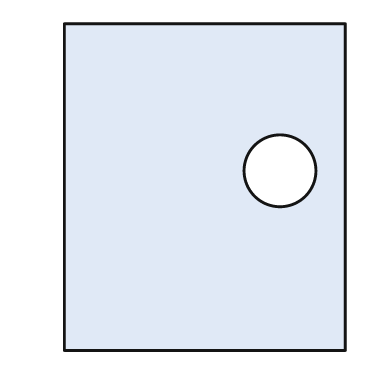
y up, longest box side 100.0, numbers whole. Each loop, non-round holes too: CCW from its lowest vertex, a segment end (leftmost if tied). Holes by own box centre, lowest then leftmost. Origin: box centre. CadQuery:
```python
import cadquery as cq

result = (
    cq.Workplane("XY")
    .moveTo(-43.0, -50.0)
    .lineTo(43.0, -50.0)
    .lineTo(43.0, 50.0)
    .lineTo(-43.0, 50.0)
    .close()
    .moveTo(23.0, 5.0)
    .circle(11.0)
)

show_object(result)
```